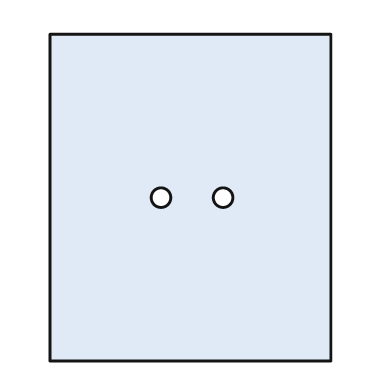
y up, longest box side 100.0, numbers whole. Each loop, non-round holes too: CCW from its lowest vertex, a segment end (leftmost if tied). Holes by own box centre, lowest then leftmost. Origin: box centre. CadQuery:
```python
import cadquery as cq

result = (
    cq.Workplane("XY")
    .moveTo(-43.0, -50.0)
    .lineTo(43.0, -50.0)
    .lineTo(43.0, 50.0)
    .lineTo(-43.0, 50.0)
    .close()
    .moveTo(-9.0, 0.0)
    .circle(3.0)
    .moveTo(10.0, 0.0)
    .circle(3.0)
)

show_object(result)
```